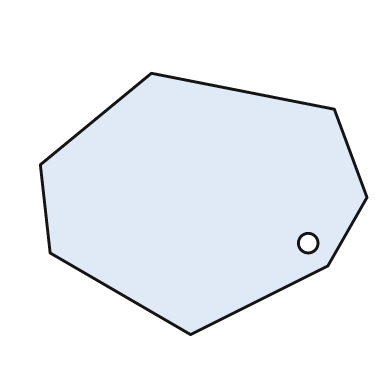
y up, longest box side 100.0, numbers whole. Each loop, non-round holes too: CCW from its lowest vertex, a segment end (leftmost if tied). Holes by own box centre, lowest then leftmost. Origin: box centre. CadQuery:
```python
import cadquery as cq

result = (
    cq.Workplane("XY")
    .moveTo(-4.0, -40.0)
    .lineTo(38.0, -19.0)
    .lineTo(50.0, 2.0)
    .lineTo(40.0, 29.0)
    .lineTo(-16.0, 40.0)
    .lineTo(-50.0, 12.0)
    .lineTo(-47.0, -15.0)
    .close()
    .moveTo(32.0, -12.0)
    .circle(3.0)
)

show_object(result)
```